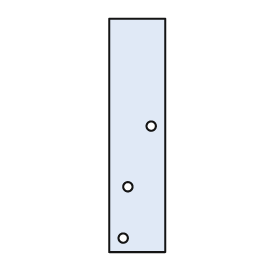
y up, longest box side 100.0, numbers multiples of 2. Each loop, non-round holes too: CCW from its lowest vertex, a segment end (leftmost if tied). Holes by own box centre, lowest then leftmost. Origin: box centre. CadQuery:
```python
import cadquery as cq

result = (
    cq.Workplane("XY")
    .moveTo(-12.0, -50.0)
    .lineTo(12.0, -50.0)
    .lineTo(12.0, 50.0)
    .lineTo(-12.0, 50.0)
    .close()
    .moveTo(-6.0, -44.0)
    .circle(2.0)
    .moveTo(-4.0, -22.0)
    .circle(2.0)
    .moveTo(6.0, 4.0)
    .circle(2.0)
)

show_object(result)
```